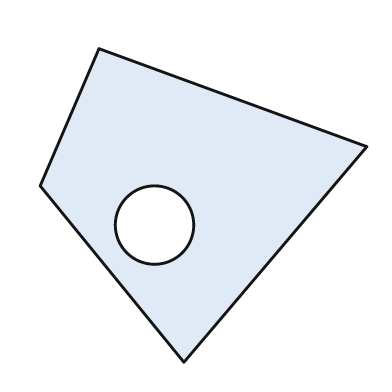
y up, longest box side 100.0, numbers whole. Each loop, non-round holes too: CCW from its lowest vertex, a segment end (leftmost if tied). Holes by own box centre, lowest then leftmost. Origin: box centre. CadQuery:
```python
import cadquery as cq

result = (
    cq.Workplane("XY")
    .moveTo(-6.0, -48.0)
    .lineTo(50.0, 18.0)
    .lineTo(-32.0, 48.0)
    .lineTo(-50.0, 6.0)
    .close()
    .moveTo(-15.0, -6.0)
    .circle(12.0)
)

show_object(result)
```